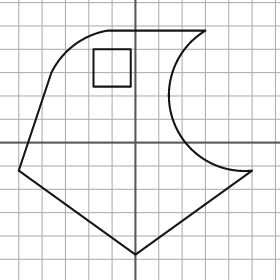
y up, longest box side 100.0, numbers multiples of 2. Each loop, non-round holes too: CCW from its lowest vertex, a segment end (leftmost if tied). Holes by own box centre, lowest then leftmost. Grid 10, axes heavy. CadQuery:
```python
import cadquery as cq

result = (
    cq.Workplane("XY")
    .moveTo(0.0, -48.0)
    .lineTo(50.0, -12.0)
    .threePointArc((16.0, 10.0), (30.0, 48.0))
    .lineTo(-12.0, 48.0)
    .threePointArc((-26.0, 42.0), (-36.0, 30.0))
    .lineTo(-50.0, -12.0)
    .close()
    .moveTo(-18.0, 24.0)
    .lineTo(-2.0, 24.0)
    .lineTo(-2.0, 40.0)
    .lineTo(-18.0, 40.0)
    .close()
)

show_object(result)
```